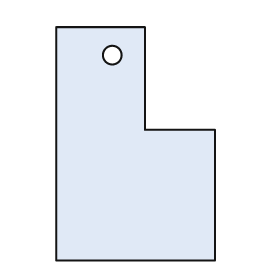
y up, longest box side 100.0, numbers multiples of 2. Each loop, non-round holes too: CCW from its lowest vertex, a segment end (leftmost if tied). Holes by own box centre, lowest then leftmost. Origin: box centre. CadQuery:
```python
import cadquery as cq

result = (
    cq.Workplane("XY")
    .moveTo(-34.0, -50.0)
    .lineTo(34.0, -50.0)
    .lineTo(34.0, 6.0)
    .lineTo(4.0, 6.0)
    .lineTo(4.0, 50.0)
    .lineTo(-34.0, 50.0)
    .close()
    .moveTo(-10.0, 38.0)
    .circle(4.0)
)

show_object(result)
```